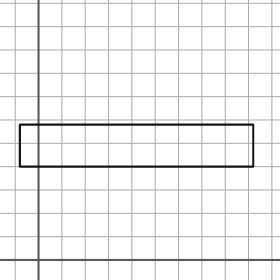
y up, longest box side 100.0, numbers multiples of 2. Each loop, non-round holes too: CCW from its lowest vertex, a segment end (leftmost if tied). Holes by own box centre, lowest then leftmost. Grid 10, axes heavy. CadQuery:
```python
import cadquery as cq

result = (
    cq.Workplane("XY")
    .moveTo(-8.0, 40.0)
    .lineTo(92.0, 40.0)
    .lineTo(92.0, 58.0)
    .lineTo(-8.0, 58.0)
    .close()
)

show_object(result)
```